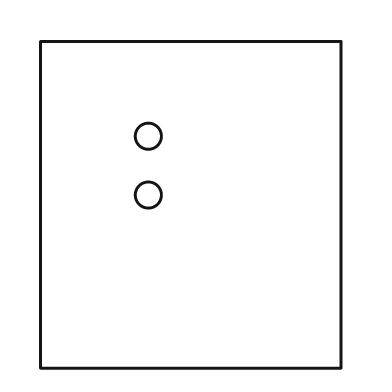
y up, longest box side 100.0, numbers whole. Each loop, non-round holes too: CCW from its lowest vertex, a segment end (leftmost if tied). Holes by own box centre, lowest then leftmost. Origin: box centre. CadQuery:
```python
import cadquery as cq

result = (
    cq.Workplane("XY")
    .moveTo(-46.0, -50.0)
    .lineTo(46.0, -50.0)
    .lineTo(46.0, 50.0)
    .lineTo(-46.0, 50.0)
    .close()
    .moveTo(-13.0, 3.0)
    .circle(4.0)
    .moveTo(-13.0, 21.0)
    .circle(4.0)
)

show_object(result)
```